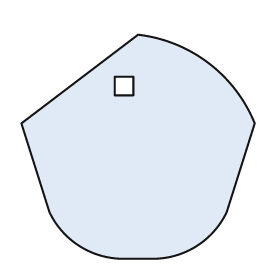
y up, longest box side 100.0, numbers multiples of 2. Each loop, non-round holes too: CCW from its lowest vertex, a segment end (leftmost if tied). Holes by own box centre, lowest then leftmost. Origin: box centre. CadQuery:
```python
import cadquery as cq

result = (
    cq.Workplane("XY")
    .moveTo(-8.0, -48.0)
    .lineTo(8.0, -48.0)
    .threePointArc((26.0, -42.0), (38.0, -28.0))
    .lineTo(50.0, 10.0)
    .threePointArc((30.0, 36.0), (0.0, 48.0))
    .lineTo(-50.0, 10.0)
    .lineTo(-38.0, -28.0)
    .threePointArc((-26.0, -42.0), (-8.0, -48.0))
    .close()
    .moveTo(-10.0, 22.0)
    .lineTo(-2.0, 22.0)
    .lineTo(-2.0, 30.0)
    .lineTo(-10.0, 30.0)
    .close()
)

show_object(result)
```